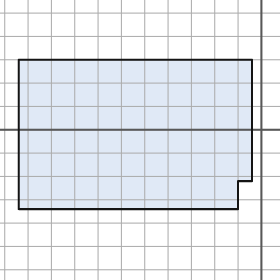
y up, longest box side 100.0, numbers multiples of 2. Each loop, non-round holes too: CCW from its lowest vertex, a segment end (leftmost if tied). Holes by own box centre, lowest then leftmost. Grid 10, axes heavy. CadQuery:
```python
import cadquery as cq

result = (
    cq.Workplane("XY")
    .moveTo(-104.0, -34.0)
    .lineTo(-10.0, -34.0)
    .lineTo(-10.0, -22.0)
    .lineTo(-4.0, -22.0)
    .lineTo(-4.0, 30.0)
    .lineTo(-104.0, 30.0)
    .close()
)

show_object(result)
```